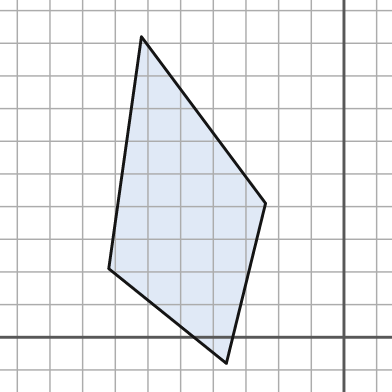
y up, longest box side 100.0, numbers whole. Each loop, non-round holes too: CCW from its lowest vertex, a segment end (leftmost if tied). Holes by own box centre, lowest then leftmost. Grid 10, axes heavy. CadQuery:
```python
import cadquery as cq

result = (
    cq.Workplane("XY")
    .moveTo(-36.0, -8.0)
    .lineTo(-24.0, 41.0)
    .lineTo(-62.0, 92.0)
    .lineTo(-72.0, 21.0)
    .close()
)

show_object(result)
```